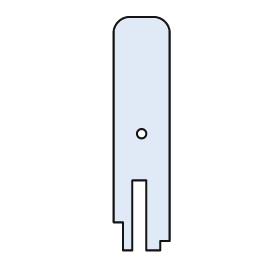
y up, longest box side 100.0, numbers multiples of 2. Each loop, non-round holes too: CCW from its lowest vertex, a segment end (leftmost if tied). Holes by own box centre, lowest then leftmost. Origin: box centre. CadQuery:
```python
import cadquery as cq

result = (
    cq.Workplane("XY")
    .moveTo(-8.0, -50.0)
    .lineTo(-4.0, -50.0)
    .lineTo(-4.0, -20.0)
    .lineTo(2.0, -20.0)
    .lineTo(2.0, -50.0)
    .lineTo(8.0, -50.0)
    .lineTo(8.0, -46.0)
    .lineTo(12.0, -46.0)
    .lineTo(12.0, 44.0)
    .threePointArc((10.0, 48.0), (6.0, 50.0))
    .lineTo(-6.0, 50.0)
    .threePointArc((-10.0, 48.0), (-12.0, 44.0))
    .lineTo(-12.0, -38.0)
    .lineTo(-8.0, -38.0)
    .close()
    .moveTo(0.0, 0.0)
    .circle(2.0)
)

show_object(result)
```